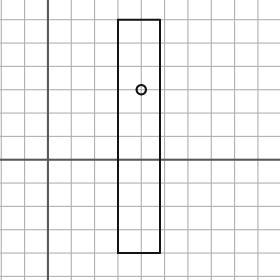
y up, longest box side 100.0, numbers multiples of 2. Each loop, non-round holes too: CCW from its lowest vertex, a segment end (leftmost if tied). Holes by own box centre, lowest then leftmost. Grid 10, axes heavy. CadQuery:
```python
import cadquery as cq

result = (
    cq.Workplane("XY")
    .moveTo(30.0, -40.0)
    .lineTo(48.0, -40.0)
    .lineTo(48.0, 60.0)
    .lineTo(30.0, 60.0)
    .close()
    .moveTo(40.0, 30.0)
    .circle(2.0)
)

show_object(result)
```